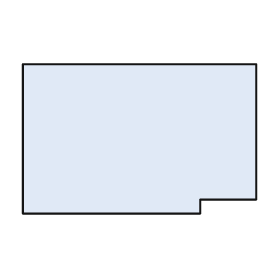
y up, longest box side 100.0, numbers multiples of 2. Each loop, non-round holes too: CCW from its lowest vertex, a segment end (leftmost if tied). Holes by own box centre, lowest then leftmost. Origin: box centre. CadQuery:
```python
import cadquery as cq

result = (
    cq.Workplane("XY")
    .moveTo(-50.0, -32.0)
    .lineTo(26.0, -32.0)
    .lineTo(26.0, -26.0)
    .lineTo(50.0, -26.0)
    .lineTo(50.0, 32.0)
    .lineTo(-50.0, 32.0)
    .close()
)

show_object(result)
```